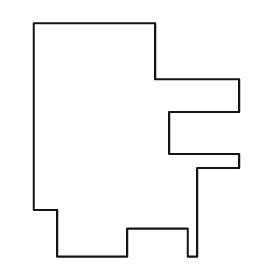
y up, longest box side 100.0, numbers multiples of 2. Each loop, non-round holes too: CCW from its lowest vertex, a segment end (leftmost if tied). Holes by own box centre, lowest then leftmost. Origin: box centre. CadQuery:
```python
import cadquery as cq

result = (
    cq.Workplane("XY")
    .moveTo(-34.0, -50.0)
    .lineTo(-4.0, -50.0)
    .lineTo(-4.0, -38.0)
    .lineTo(22.0, -38.0)
    .lineTo(22.0, -50.0)
    .lineTo(26.0, -50.0)
    .lineTo(26.0, -12.0)
    .lineTo(44.0, -12.0)
    .lineTo(44.0, -6.0)
    .lineTo(14.0, -6.0)
    .lineTo(14.0, 12.0)
    .lineTo(44.0, 12.0)
    .lineTo(44.0, 26.0)
    .lineTo(8.0, 26.0)
    .lineTo(8.0, 50.0)
    .lineTo(-44.0, 50.0)
    .lineTo(-44.0, -30.0)
    .lineTo(-34.0, -30.0)
    .close()
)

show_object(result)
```